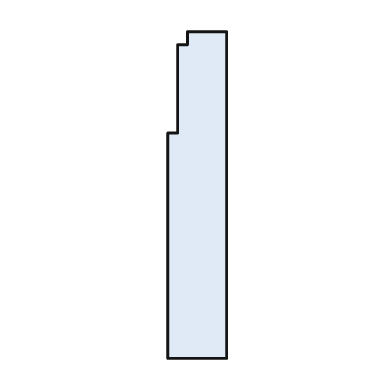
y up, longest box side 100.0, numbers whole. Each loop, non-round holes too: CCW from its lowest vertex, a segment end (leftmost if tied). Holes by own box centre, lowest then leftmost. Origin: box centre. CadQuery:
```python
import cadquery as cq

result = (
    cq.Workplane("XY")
    .moveTo(-9.0, -50.0)
    .lineTo(9.0, -50.0)
    .lineTo(9.0, 50.0)
    .lineTo(-3.0, 50.0)
    .lineTo(-3.0, 46.0)
    .lineTo(-6.0, 46.0)
    .lineTo(-6.0, 19.0)
    .lineTo(-9.0, 19.0)
    .close()
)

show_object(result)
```